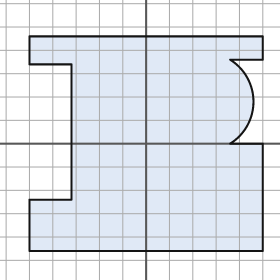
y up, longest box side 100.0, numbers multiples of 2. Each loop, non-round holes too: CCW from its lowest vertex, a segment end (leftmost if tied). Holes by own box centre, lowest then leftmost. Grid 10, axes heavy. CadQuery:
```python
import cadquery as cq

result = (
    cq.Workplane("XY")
    .moveTo(-50.0, -46.0)
    .lineTo(50.0, -46.0)
    .lineTo(50.0, 0.0)
    .lineTo(36.0, 0.0)
    .threePointArc((46.0, 18.0), (36.0, 36.0))
    .lineTo(50.0, 36.0)
    .lineTo(50.0, 46.0)
    .lineTo(-50.0, 46.0)
    .lineTo(-50.0, 34.0)
    .lineTo(-32.0, 34.0)
    .lineTo(-32.0, -24.0)
    .lineTo(-50.0, -24.0)
    .close()
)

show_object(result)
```